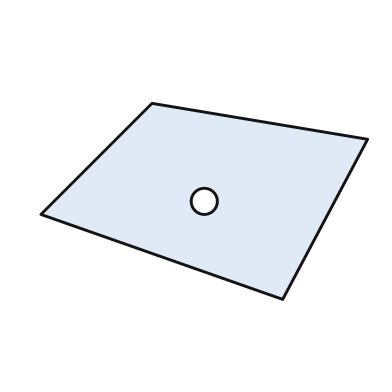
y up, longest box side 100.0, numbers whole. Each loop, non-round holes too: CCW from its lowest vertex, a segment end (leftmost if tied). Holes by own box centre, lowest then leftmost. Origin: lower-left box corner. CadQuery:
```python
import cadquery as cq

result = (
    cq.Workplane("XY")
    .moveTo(74.0, 0.0)
    .lineTo(100.0, 49.0)
    .lineTo(34.0, 60.0)
    .lineTo(0.0, 26.0)
    .close()
    .moveTo(50.0, 30.0)
    .circle(4.0)
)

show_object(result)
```